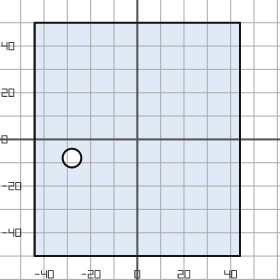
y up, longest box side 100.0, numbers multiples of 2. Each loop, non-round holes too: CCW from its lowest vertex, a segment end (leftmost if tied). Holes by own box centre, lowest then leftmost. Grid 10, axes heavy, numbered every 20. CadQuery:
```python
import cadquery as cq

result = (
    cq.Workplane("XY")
    .moveTo(-44.0, -50.0)
    .lineTo(44.0, -50.0)
    .lineTo(44.0, 50.0)
    .lineTo(-44.0, 50.0)
    .close()
    .moveTo(-28.0, -8.0)
    .circle(4.0)
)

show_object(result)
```